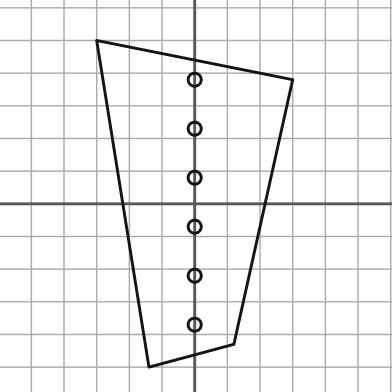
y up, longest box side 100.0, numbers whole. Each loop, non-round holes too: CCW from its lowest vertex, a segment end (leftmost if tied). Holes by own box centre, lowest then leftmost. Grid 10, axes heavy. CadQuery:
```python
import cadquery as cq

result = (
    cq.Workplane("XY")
    .moveTo(-14.0, -50.0)
    .lineTo(12.0, -43.0)
    .lineTo(30.0, 38.0)
    .lineTo(-30.0, 50.0)
    .close()
    .moveTo(0.0, -37.0)
    .circle(2.0)
    .moveTo(0.0, -22.0)
    .circle(2.0)
    .moveTo(0.0, -7.0)
    .circle(2.0)
    .moveTo(0.0, 8.0)
    .circle(2.0)
    .moveTo(0.0, 23.0)
    .circle(2.0)
    .moveTo(0.0, 38.0)
    .circle(2.0)
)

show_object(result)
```